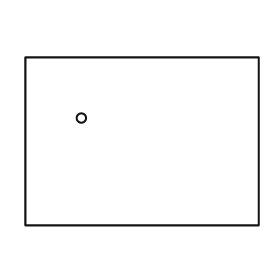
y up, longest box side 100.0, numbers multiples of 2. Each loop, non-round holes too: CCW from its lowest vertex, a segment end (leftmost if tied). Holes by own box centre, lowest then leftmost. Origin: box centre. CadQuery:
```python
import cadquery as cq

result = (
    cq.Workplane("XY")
    .moveTo(-50.0, -36.0)
    .lineTo(50.0, -36.0)
    .lineTo(50.0, 36.0)
    .lineTo(-50.0, 36.0)
    .close()
    .moveTo(-26.0, 10.0)
    .circle(2.0)
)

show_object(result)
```